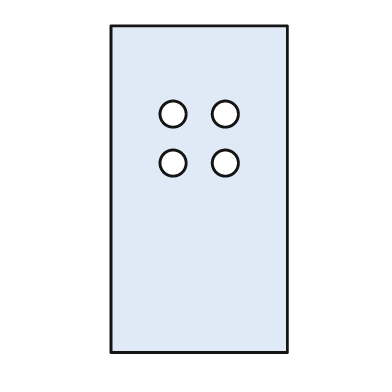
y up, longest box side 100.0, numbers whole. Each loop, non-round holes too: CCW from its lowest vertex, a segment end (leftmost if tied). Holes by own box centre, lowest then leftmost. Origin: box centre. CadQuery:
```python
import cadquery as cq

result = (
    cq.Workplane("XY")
    .moveTo(-27.0, -50.0)
    .lineTo(27.0, -50.0)
    .lineTo(27.0, 50.0)
    .lineTo(-27.0, 50.0)
    .close()
    .moveTo(-8.0, 8.0)
    .circle(4.0)
    .moveTo(8.0, 8.0)
    .circle(4.0)
    .moveTo(-8.0, 23.0)
    .circle(4.0)
    .moveTo(8.0, 23.0)
    .circle(4.0)
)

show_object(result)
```